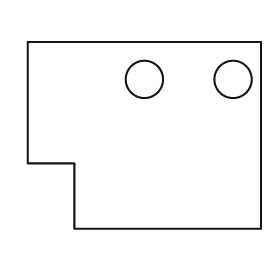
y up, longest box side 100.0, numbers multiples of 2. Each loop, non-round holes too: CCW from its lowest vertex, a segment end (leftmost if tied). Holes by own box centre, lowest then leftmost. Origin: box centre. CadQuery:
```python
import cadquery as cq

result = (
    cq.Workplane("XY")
    .moveTo(-30.0, -40.0)
    .lineTo(50.0, -40.0)
    .lineTo(50.0, 40.0)
    .lineTo(-50.0, 40.0)
    .lineTo(-50.0, -12.0)
    .lineTo(-30.0, -12.0)
    .close()
    .moveTo(0.0, 24.0)
    .circle(8.0)
    .moveTo(38.0, 24.0)
    .circle(8.0)
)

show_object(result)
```